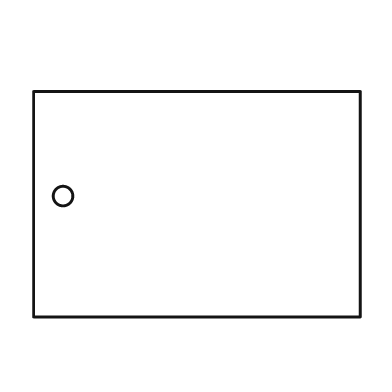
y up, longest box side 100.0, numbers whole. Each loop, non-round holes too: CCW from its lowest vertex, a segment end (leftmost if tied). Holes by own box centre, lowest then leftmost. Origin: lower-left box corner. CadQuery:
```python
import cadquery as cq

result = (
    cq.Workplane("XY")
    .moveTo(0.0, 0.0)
    .lineTo(100.0, 0.0)
    .lineTo(100.0, 69.0)
    .lineTo(0.0, 69.0)
    .close()
    .moveTo(9.0, 37.0)
    .circle(3.0)
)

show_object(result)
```